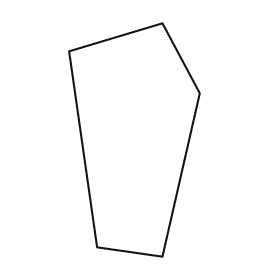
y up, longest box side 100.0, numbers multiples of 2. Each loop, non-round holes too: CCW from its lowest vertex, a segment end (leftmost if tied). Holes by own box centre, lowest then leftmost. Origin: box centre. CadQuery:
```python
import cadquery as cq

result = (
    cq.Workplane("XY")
    .moveTo(12.0, -50.0)
    .lineTo(28.0, 20.0)
    .lineTo(12.0, 50.0)
    .lineTo(-28.0, 38.0)
    .lineTo(-16.0, -46.0)
    .close()
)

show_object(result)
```